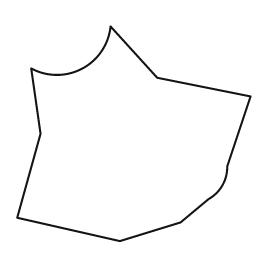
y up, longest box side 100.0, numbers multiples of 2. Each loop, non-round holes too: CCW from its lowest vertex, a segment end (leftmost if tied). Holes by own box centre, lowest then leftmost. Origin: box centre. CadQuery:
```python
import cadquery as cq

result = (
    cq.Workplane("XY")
    .moveTo(-6.0, -46.0)
    .lineTo(20.0, -38.0)
    .lineTo(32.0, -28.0)
    .threePointArc((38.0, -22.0), (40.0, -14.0))
    .lineTo(50.0, 16.0)
    .lineTo(10.0, 24.0)
    .lineTo(-10.0, 46.0)
    .threePointArc((-22.0, 28.0), (-44.0, 28.0))
    .lineTo(-40.0, 0.0)
    .lineTo(-50.0, -36.0)
    .close()
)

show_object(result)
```